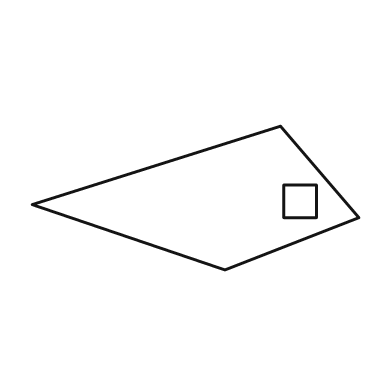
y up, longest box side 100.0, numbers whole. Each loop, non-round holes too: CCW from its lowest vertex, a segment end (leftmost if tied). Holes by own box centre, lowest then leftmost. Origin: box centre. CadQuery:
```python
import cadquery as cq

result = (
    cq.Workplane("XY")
    .moveTo(9.0, -22.0)
    .lineTo(50.0, -6.0)
    .lineTo(26.0, 22.0)
    .lineTo(-50.0, -2.0)
    .close()
    .moveTo(27.0, -6.0)
    .lineTo(37.0, -6.0)
    .lineTo(37.0, 4.0)
    .lineTo(27.0, 4.0)
    .close()
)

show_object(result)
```